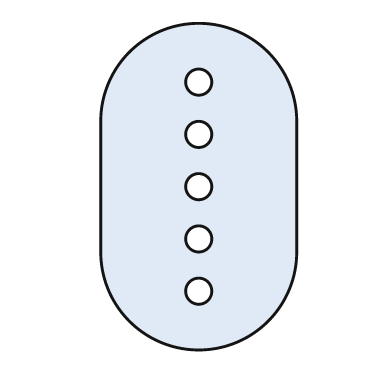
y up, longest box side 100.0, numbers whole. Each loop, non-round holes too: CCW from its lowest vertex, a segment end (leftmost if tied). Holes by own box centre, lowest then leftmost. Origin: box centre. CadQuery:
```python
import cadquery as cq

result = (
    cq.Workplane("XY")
    .moveTo(-30.0, -20.0)
    .threePointArc((0.0, -50.0), (30.0, -20.0))
    .lineTo(30.0, 20.0)
    .threePointArc((0.0, 50.0), (-30.0, 20.0))
    .close()
    .moveTo(0.0, -32.0)
    .circle(4.0)
    .moveTo(0.0, -16.0)
    .circle(4.0)
    .moveTo(0.0, 0.0)
    .circle(4.0)
    .moveTo(0.0, 16.0)
    .circle(4.0)
    .moveTo(0.0, 32.0)
    .circle(4.0)
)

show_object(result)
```